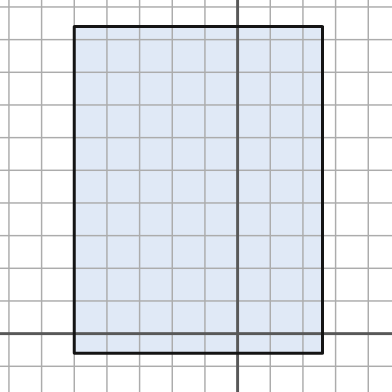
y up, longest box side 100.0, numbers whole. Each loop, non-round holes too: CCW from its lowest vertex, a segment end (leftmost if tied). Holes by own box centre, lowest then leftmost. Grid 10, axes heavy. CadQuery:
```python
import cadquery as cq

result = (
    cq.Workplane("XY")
    .moveTo(-50.0, -6.0)
    .lineTo(26.0, -6.0)
    .lineTo(26.0, 94.0)
    .lineTo(-50.0, 94.0)
    .close()
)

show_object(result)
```